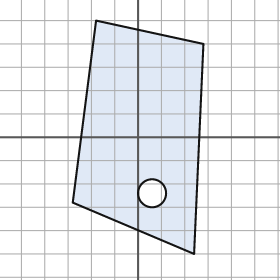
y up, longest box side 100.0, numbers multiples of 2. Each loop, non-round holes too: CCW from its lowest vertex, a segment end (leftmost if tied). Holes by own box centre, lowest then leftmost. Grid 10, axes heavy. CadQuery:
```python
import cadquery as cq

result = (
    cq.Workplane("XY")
    .moveTo(24.0, -50.0)
    .lineTo(28.0, 40.0)
    .lineTo(-18.0, 50.0)
    .lineTo(-28.0, -28.0)
    .close()
    .moveTo(6.0, -24.0)
    .circle(6.0)
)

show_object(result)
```